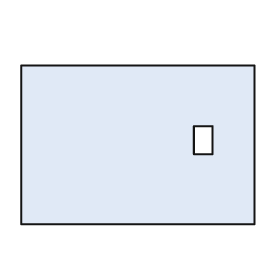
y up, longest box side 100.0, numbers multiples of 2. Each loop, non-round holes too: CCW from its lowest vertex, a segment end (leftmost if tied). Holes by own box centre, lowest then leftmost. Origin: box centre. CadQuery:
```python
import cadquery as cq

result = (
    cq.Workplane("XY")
    .moveTo(-50.0, -34.0)
    .lineTo(50.0, -34.0)
    .lineTo(50.0, 34.0)
    .lineTo(-50.0, 34.0)
    .close()
    .moveTo(24.0, -4.0)
    .lineTo(32.0, -4.0)
    .lineTo(32.0, 8.0)
    .lineTo(24.0, 8.0)
    .close()
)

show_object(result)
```